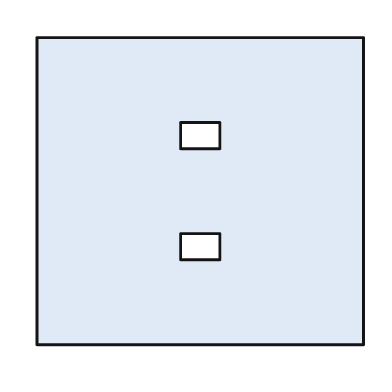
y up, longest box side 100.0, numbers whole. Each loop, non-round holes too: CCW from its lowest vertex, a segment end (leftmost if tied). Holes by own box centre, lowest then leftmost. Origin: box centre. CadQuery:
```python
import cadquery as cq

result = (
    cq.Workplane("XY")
    .moveTo(-50.0, -47.0)
    .lineTo(50.0, -47.0)
    .lineTo(50.0, 47.0)
    .lineTo(-50.0, 47.0)
    .close()
    .moveTo(-6.0, -21.0)
    .lineTo(6.0, -21.0)
    .lineTo(6.0, -13.0)
    .lineTo(-6.0, -13.0)
    .close()
    .moveTo(-6.0, 13.0)
    .lineTo(6.0, 13.0)
    .lineTo(6.0, 21.0)
    .lineTo(-6.0, 21.0)
    .close()
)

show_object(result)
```